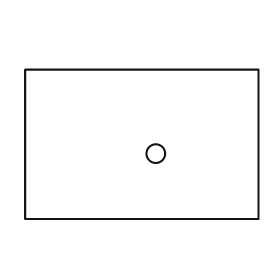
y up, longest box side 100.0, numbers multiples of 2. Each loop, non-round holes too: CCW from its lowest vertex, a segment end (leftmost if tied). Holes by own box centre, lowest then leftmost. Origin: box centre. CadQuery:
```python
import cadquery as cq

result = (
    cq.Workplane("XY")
    .moveTo(-50.0, -32.0)
    .lineTo(50.0, -32.0)
    .lineTo(50.0, 32.0)
    .lineTo(-50.0, 32.0)
    .close()
    .moveTo(6.0, -4.0)
    .circle(4.0)
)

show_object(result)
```